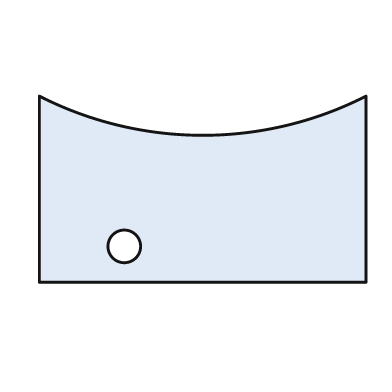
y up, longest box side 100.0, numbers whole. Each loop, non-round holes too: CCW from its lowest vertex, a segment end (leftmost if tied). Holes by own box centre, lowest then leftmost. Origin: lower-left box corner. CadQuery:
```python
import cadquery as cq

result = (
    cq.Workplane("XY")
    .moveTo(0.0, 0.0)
    .lineTo(100.0, 0.0)
    .lineTo(100.0, 57.0)
    .threePointArc((50.0, 45.0), (0.0, 57.0))
    .close()
    .moveTo(26.0, 11.0)
    .circle(5.0)
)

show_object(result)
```